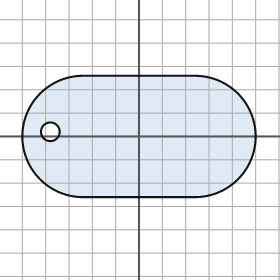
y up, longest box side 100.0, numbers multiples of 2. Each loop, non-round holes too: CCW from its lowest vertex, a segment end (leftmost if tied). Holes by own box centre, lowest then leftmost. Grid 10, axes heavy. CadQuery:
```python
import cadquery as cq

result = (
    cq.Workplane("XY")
    .moveTo(-24.0, -26.0)
    .lineTo(24.0, -26.0)
    .threePointArc((50.0, 0.0), (24.0, 26.0))
    .lineTo(-24.0, 26.0)
    .threePointArc((-50.0, 0.0), (-24.0, -26.0))
    .close()
    .moveTo(-38.0, 2.0)
    .circle(4.0)
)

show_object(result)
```